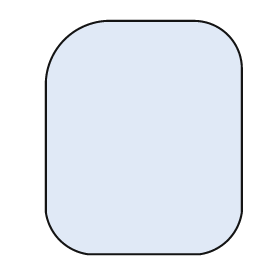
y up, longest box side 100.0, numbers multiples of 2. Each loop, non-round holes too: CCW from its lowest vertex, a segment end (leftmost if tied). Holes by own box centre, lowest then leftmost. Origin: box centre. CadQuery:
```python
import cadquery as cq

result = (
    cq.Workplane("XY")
    .moveTo(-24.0, -50.0)
    .lineTo(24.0, -50.0)
    .threePointArc((36.0, -44.0), (42.0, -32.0))
    .lineTo(42.0, 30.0)
    .threePointArc((36.0, 44.0), (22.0, 50.0))
    .lineTo(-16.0, 50.0)
    .threePointArc((-34.0, 42.0), (-42.0, 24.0))
    .lineTo(-42.0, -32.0)
    .threePointArc((-36.0, -44.0), (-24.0, -50.0))
    .close()
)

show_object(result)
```